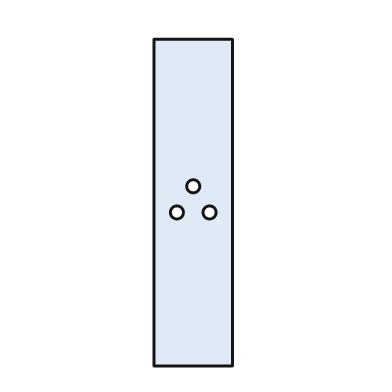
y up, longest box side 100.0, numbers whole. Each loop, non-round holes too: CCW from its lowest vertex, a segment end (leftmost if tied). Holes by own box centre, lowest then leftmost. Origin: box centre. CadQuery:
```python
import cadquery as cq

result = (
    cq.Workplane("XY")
    .moveTo(-12.0, -50.0)
    .lineTo(12.0, -50.0)
    .lineTo(12.0, 50.0)
    .lineTo(-12.0, 50.0)
    .close()
    .moveTo(-5.0, -3.0)
    .circle(2.0)
    .moveTo(5.0, -3.0)
    .circle(2.0)
    .moveTo(0.0, 5.0)
    .circle(2.0)
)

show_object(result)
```